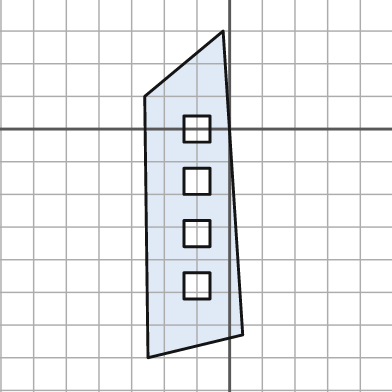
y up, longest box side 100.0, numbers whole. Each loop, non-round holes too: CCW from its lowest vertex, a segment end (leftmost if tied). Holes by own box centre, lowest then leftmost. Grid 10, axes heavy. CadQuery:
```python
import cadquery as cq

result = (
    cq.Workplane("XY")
    .moveTo(-25.0, -70.0)
    .lineTo(4.0, -63.0)
    .lineTo(-2.0, 30.0)
    .lineTo(-26.0, 10.0)
    .close()
    .moveTo(-14.0, -52.0)
    .lineTo(-6.0, -52.0)
    .lineTo(-6.0, -44.0)
    .lineTo(-14.0, -44.0)
    .close()
    .moveTo(-14.0, -36.0)
    .lineTo(-6.0, -36.0)
    .lineTo(-6.0, -28.0)
    .lineTo(-14.0, -28.0)
    .close()
    .moveTo(-14.0, -20.0)
    .lineTo(-6.0, -20.0)
    .lineTo(-6.0, -12.0)
    .lineTo(-14.0, -12.0)
    .close()
    .moveTo(-14.0, -4.0)
    .lineTo(-6.0, -4.0)
    .lineTo(-6.0, 4.0)
    .lineTo(-14.0, 4.0)
    .close()
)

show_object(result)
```